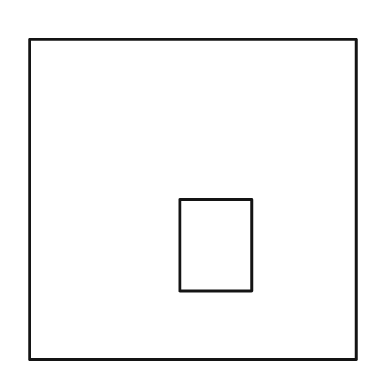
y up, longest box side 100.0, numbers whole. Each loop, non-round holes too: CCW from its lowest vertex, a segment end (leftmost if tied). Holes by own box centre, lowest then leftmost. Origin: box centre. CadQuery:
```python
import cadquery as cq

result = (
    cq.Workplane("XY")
    .moveTo(-50.0, -49.0)
    .lineTo(50.0, -49.0)
    .lineTo(50.0, 49.0)
    .lineTo(-50.0, 49.0)
    .close()
    .moveTo(-4.0, -28.0)
    .lineTo(18.0, -28.0)
    .lineTo(18.0, 0.0)
    .lineTo(-4.0, 0.0)
    .close()
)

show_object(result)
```